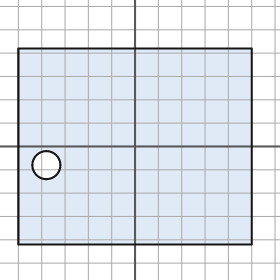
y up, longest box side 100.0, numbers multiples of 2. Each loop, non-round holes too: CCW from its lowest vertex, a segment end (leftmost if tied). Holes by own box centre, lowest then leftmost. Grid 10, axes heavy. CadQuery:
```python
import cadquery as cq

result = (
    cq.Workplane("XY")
    .moveTo(-50.0, -42.0)
    .lineTo(50.0, -42.0)
    .lineTo(50.0, 42.0)
    .lineTo(-50.0, 42.0)
    .close()
    .moveTo(-38.0, -8.0)
    .circle(6.0)
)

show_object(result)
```